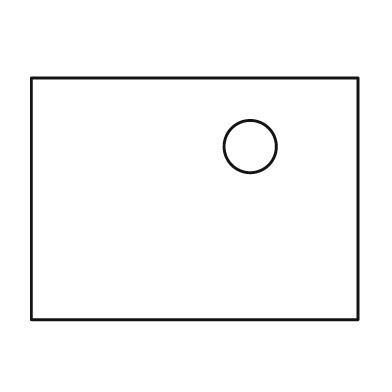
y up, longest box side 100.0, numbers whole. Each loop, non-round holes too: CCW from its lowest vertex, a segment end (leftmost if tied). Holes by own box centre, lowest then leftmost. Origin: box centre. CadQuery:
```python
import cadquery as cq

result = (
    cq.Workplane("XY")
    .moveTo(-50.0, -37.0)
    .lineTo(50.0, -37.0)
    .lineTo(50.0, 37.0)
    .lineTo(-50.0, 37.0)
    .close()
    .moveTo(17.0, 16.0)
    .circle(8.0)
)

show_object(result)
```